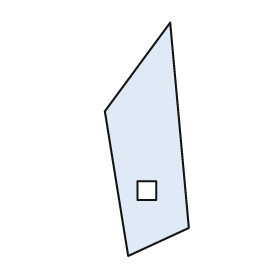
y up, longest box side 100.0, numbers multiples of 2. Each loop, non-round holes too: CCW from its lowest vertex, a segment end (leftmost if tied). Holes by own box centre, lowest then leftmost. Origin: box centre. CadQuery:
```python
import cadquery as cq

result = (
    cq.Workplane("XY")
    .moveTo(-8.0, -50.0)
    .lineTo(18.0, -38.0)
    .lineTo(10.0, 50.0)
    .lineTo(-18.0, 12.0)
    .close()
    .moveTo(-4.0, -26.0)
    .lineTo(4.0, -26.0)
    .lineTo(4.0, -18.0)
    .lineTo(-4.0, -18.0)
    .close()
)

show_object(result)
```